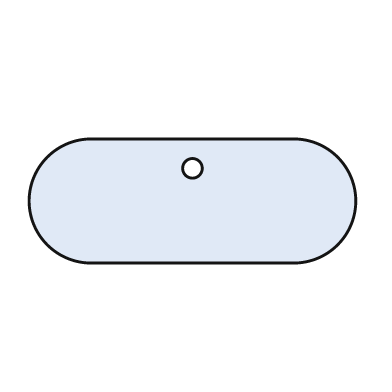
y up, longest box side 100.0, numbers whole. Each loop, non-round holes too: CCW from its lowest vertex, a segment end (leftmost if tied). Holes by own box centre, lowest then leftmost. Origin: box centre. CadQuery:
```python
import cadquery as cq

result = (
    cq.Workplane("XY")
    .moveTo(-31.0, -19.0)
    .lineTo(31.0, -19.0)
    .threePointArc((50.0, 0.0), (31.0, 19.0))
    .lineTo(-31.0, 19.0)
    .threePointArc((-50.0, 0.0), (-31.0, -19.0))
    .close()
    .moveTo(0.0, 10.0)
    .circle(3.0)
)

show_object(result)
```